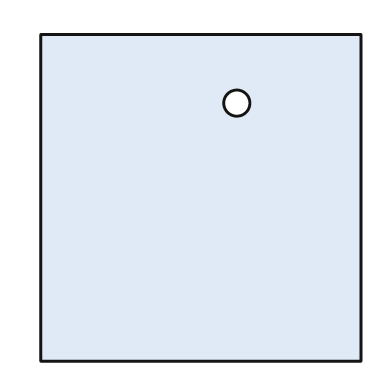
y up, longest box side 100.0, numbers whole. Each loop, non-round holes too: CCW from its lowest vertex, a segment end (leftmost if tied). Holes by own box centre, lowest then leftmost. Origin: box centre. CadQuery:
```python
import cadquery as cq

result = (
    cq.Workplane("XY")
    .moveTo(-49.0, -50.0)
    .lineTo(49.0, -50.0)
    .lineTo(49.0, 50.0)
    .lineTo(-49.0, 50.0)
    .close()
    .moveTo(11.0, 29.0)
    .circle(4.0)
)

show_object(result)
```